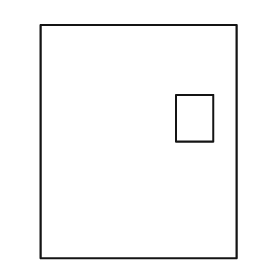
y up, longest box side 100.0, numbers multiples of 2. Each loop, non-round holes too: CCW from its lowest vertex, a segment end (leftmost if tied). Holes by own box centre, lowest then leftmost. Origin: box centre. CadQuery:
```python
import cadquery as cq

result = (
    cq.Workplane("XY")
    .moveTo(-42.0, -50.0)
    .lineTo(42.0, -50.0)
    .lineTo(42.0, 50.0)
    .lineTo(-42.0, 50.0)
    .close()
    .moveTo(16.0, 0.0)
    .lineTo(32.0, 0.0)
    .lineTo(32.0, 20.0)
    .lineTo(16.0, 20.0)
    .close()
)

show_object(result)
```